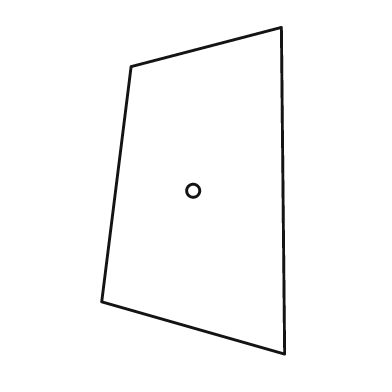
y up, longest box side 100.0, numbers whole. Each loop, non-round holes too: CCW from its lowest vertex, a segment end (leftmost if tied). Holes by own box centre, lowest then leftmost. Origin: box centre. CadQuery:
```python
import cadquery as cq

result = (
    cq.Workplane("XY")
    .moveTo(28.0, -50.0)
    .lineTo(27.0, 50.0)
    .lineTo(-19.0, 38.0)
    .lineTo(-28.0, -34.0)
    .close()
    .moveTo(0.0, 0.0)
    .circle(2.0)
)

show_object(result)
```